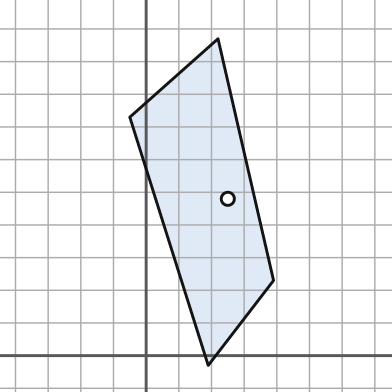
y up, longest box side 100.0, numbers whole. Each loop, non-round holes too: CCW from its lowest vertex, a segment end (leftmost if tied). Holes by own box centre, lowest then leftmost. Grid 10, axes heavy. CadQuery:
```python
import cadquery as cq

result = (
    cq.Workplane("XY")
    .moveTo(19.0, -3.0)
    .lineTo(39.0, 23.0)
    .lineTo(22.0, 97.0)
    .lineTo(-5.0, 73.0)
    .close()
    .moveTo(25.0, 48.0)
    .circle(2.0)
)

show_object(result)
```